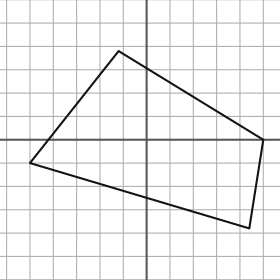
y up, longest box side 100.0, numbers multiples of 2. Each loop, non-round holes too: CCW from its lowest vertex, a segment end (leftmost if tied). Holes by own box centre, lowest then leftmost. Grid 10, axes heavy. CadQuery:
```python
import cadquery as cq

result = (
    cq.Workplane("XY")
    .moveTo(44.0, -38.0)
    .lineTo(50.0, 0.0)
    .lineTo(-12.0, 38.0)
    .lineTo(-50.0, -10.0)
    .close()
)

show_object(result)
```